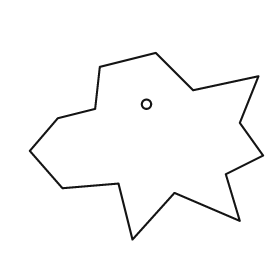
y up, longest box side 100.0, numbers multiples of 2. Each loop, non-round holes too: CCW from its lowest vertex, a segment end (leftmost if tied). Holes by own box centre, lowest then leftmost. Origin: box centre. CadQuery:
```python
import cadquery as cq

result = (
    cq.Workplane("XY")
    .moveTo(-6.0, -40.0)
    .lineTo(12.0, -20.0)
    .lineTo(40.0, -32.0)
    .lineTo(34.0, -12.0)
    .lineTo(50.0, -4.0)
    .lineTo(40.0, 10.0)
    .lineTo(48.0, 30.0)
    .lineTo(20.0, 24.0)
    .lineTo(4.0, 40.0)
    .lineTo(-20.0, 34.0)
    .lineTo(-22.0, 16.0)
    .lineTo(-38.0, 12.0)
    .lineTo(-50.0, -2.0)
    .lineTo(-36.0, -18.0)
    .lineTo(-12.0, -16.0)
    .close()
    .moveTo(0.0, 18.0)
    .circle(2.0)
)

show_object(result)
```